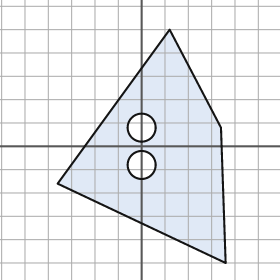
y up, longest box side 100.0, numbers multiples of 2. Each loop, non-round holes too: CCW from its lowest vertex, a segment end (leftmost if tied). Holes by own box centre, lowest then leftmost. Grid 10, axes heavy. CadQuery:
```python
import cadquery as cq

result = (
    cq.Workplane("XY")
    .moveTo(36.0, -50.0)
    .lineTo(34.0, 8.0)
    .lineTo(12.0, 50.0)
    .lineTo(-36.0, -16.0)
    .close()
    .moveTo(0.0, -8.0)
    .circle(6.0)
    .moveTo(0.0, 8.0)
    .circle(6.0)
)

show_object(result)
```